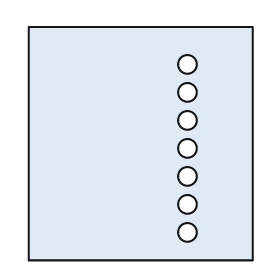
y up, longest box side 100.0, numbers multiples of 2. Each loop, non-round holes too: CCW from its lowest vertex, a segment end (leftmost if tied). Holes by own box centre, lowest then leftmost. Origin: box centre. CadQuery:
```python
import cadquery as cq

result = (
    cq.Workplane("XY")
    .moveTo(-48.0, -50.0)
    .lineTo(48.0, -50.0)
    .lineTo(48.0, 50.0)
    .lineTo(-48.0, 50.0)
    .close()
    .moveTo(20.0, -38.0)
    .circle(4.0)
    .moveTo(20.0, -26.0)
    .circle(4.0)
    .moveTo(20.0, -14.0)
    .circle(4.0)
    .moveTo(20.0, -2.0)
    .circle(4.0)
    .moveTo(20.0, 10.0)
    .circle(4.0)
    .moveTo(20.0, 22.0)
    .circle(4.0)
    .moveTo(20.0, 34.0)
    .circle(4.0)
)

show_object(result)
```